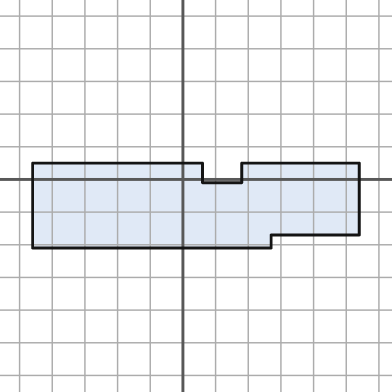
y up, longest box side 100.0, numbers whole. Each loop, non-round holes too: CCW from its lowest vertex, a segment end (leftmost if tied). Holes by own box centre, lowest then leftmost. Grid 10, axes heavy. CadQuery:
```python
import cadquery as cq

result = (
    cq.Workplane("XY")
    .moveTo(-46.0, -21.0)
    .lineTo(27.0, -21.0)
    .lineTo(27.0, -17.0)
    .lineTo(54.0, -17.0)
    .lineTo(54.0, 5.0)
    .lineTo(18.0, 5.0)
    .lineTo(18.0, -1.0)
    .lineTo(6.0, -1.0)
    .lineTo(6.0, 5.0)
    .lineTo(-46.0, 5.0)
    .close()
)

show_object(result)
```